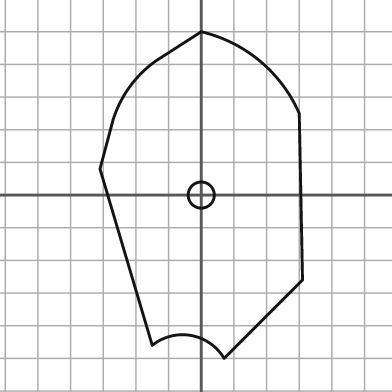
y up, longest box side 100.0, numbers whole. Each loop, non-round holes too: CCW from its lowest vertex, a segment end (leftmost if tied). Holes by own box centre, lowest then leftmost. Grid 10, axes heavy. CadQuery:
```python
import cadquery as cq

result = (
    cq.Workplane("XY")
    .moveTo(7.0, -50.0)
    .lineTo(31.0, -26.0)
    .lineTo(30.0, 25.0)
    .threePointArc((18.0, 41.0), (0.0, 50.0))
    .lineTo(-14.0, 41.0)
    .threePointArc((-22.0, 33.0), (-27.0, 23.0))
    .lineTo(-31.0, 8.0)
    .lineTo(-15.0, -46.0)
    .threePointArc((-3.0, -43.0), (7.0, -50.0))
    .close()
    .moveTo(0.0, 0.0)
    .circle(4.0)
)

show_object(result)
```